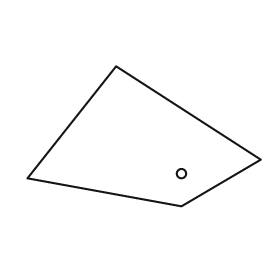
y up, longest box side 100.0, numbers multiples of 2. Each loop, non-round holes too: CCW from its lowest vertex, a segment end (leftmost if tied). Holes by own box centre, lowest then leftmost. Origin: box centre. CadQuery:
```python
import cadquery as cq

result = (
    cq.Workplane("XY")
    .moveTo(16.0, -30.0)
    .lineTo(50.0, -10.0)
    .lineTo(-12.0, 30.0)
    .lineTo(-50.0, -18.0)
    .close()
    .moveTo(16.0, -16.0)
    .circle(2.0)
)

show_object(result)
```